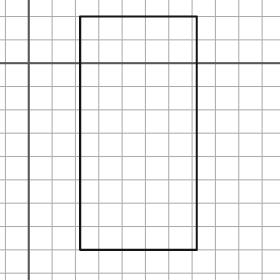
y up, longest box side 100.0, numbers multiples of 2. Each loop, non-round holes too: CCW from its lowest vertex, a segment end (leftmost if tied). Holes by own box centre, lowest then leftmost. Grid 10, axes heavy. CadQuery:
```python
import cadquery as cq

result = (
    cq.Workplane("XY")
    .moveTo(22.0, -80.0)
    .lineTo(72.0, -80.0)
    .lineTo(72.0, 20.0)
    .lineTo(22.0, 20.0)
    .close()
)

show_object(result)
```